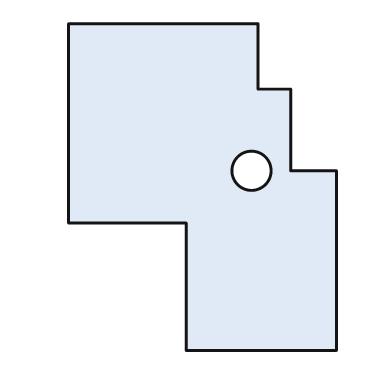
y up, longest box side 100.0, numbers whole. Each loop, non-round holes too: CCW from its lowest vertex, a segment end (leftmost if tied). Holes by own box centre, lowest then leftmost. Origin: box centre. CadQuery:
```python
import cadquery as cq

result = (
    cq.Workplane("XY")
    .moveTo(-5.0, -50.0)
    .lineTo(41.0, -50.0)
    .lineTo(41.0, 5.0)
    .lineTo(27.0, 5.0)
    .lineTo(27.0, 30.0)
    .lineTo(17.0, 30.0)
    .lineTo(17.0, 50.0)
    .lineTo(-41.0, 50.0)
    .lineTo(-41.0, -11.0)
    .lineTo(-5.0, -11.0)
    .close()
    .moveTo(15.0, 5.0)
    .circle(6.0)
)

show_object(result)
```